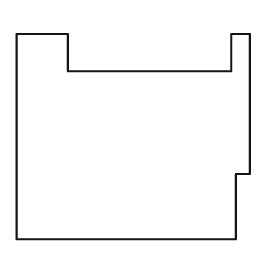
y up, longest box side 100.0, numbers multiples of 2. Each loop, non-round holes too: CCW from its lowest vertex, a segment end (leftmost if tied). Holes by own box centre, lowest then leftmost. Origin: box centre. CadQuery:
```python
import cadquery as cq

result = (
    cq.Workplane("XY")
    .moveTo(-50.0, -44.0)
    .lineTo(44.0, -44.0)
    .lineTo(44.0, -16.0)
    .lineTo(50.0, -16.0)
    .lineTo(50.0, 44.0)
    .lineTo(42.0, 44.0)
    .lineTo(42.0, 28.0)
    .lineTo(-28.0, 28.0)
    .lineTo(-28.0, 44.0)
    .lineTo(-50.0, 44.0)
    .close()
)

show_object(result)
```